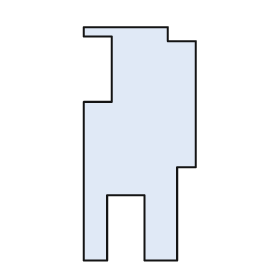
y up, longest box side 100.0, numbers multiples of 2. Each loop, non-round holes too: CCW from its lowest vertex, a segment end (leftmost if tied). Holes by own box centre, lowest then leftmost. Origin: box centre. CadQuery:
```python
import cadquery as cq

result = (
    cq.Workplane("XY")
    .moveTo(-24.0, -50.0)
    .lineTo(-14.0, -50.0)
    .lineTo(-14.0, -22.0)
    .lineTo(2.0, -22.0)
    .lineTo(2.0, -50.0)
    .lineTo(16.0, -50.0)
    .lineTo(16.0, -10.0)
    .lineTo(24.0, -10.0)
    .lineTo(24.0, 44.0)
    .lineTo(12.0, 44.0)
    .lineTo(12.0, 50.0)
    .lineTo(-24.0, 50.0)
    .lineTo(-24.0, 46.0)
    .lineTo(-12.0, 46.0)
    .lineTo(-12.0, 18.0)
    .lineTo(-24.0, 18.0)
    .close()
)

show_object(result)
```